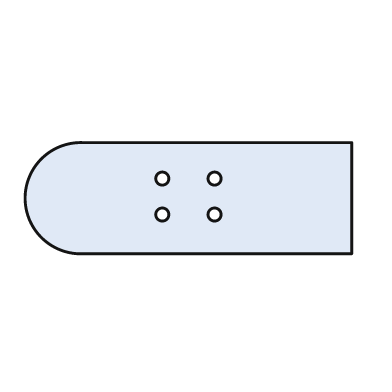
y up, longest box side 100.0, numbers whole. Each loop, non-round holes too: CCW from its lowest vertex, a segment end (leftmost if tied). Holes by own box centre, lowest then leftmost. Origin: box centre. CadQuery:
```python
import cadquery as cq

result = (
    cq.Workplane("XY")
    .moveTo(-32.0, -17.0)
    .lineTo(50.0, -17.0)
    .lineTo(50.0, 17.0)
    .lineTo(-32.0, 17.0)
    .threePointArc((-50.0, 0.0), (-32.0, -17.0))
    .close()
    .moveTo(-8.0, -5.0)
    .circle(2.0)
    .moveTo(8.0, -5.0)
    .circle(2.0)
    .moveTo(-8.0, 6.0)
    .circle(2.0)
    .moveTo(8.0, 6.0)
    .circle(2.0)
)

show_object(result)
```